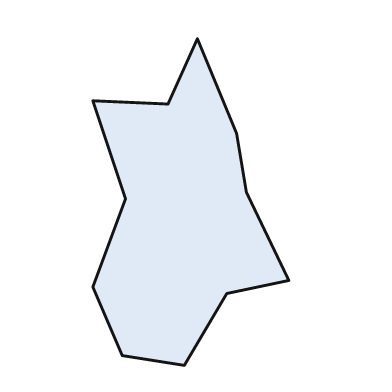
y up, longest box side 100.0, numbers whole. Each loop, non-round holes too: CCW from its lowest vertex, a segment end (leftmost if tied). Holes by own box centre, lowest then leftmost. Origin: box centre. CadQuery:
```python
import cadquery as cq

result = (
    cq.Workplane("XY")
    .moveTo(-2.0, -50.0)
    .lineTo(11.0, -28.0)
    .lineTo(30.0, -24.0)
    .lineTo(17.0, 3.0)
    .lineTo(14.0, 21.0)
    .lineTo(2.0, 50.0)
    .lineTo(-7.0, 30.0)
    .lineTo(-30.0, 31.0)
    .lineTo(-20.0, 1.0)
    .lineTo(-30.0, -26.0)
    .lineTo(-21.0, -47.0)
    .close()
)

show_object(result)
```